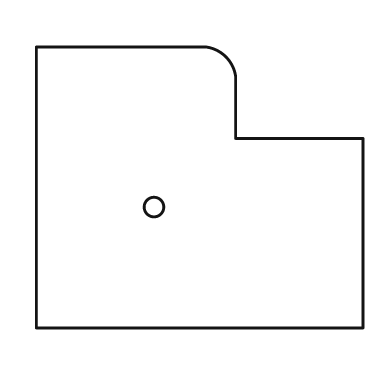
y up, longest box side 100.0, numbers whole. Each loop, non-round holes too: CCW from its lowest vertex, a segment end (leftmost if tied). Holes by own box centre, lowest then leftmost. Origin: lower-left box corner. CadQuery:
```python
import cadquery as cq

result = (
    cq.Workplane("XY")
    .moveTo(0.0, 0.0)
    .lineTo(100.0, 0.0)
    .lineTo(100.0, 58.0)
    .lineTo(61.0, 58.0)
    .lineTo(61.0, 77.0)
    .threePointArc((58.0, 83.0), (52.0, 86.0))
    .lineTo(0.0, 86.0)
    .close()
    .moveTo(36.0, 37.0)
    .circle(3.0)
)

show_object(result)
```